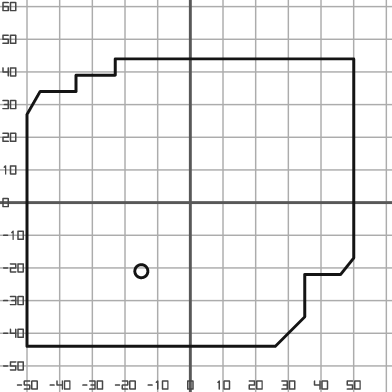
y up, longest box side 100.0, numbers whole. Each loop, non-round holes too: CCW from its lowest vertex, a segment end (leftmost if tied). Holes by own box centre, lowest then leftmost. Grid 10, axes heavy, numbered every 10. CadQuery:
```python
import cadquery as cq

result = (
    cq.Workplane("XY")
    .moveTo(-50.0, -44.0)
    .lineTo(26.0, -44.0)
    .lineTo(35.0, -35.0)
    .lineTo(35.0, -22.0)
    .lineTo(46.0, -22.0)
    .lineTo(50.0, -17.0)
    .lineTo(50.0, 44.0)
    .lineTo(-23.0, 44.0)
    .lineTo(-23.0, 39.0)
    .lineTo(-35.0, 39.0)
    .lineTo(-35.0, 34.0)
    .lineTo(-46.0, 34.0)
    .lineTo(-50.0, 27.0)
    .close()
    .moveTo(-15.0, -21.0)
    .circle(2.0)
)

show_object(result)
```